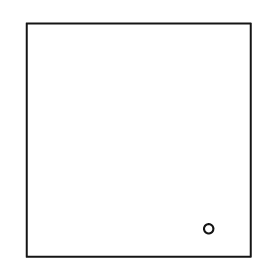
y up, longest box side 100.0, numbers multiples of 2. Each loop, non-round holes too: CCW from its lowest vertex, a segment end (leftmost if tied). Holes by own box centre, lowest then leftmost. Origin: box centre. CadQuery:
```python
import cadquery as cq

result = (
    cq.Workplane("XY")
    .moveTo(-48.0, -50.0)
    .lineTo(48.0, -50.0)
    .lineTo(48.0, 50.0)
    .lineTo(-48.0, 50.0)
    .close()
    .moveTo(30.0, -38.0)
    .circle(2.0)
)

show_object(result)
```